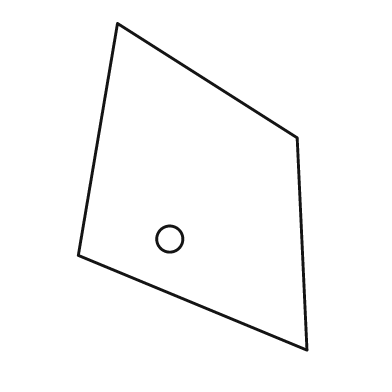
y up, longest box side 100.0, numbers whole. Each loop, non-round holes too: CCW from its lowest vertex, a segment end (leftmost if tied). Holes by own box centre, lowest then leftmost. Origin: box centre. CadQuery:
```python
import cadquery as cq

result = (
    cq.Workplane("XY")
    .moveTo(35.0, -50.0)
    .lineTo(32.0, 15.0)
    .lineTo(-23.0, 50.0)
    .lineTo(-35.0, -21.0)
    .close()
    .moveTo(-7.0, -16.0)
    .circle(4.0)
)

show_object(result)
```